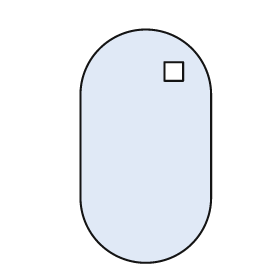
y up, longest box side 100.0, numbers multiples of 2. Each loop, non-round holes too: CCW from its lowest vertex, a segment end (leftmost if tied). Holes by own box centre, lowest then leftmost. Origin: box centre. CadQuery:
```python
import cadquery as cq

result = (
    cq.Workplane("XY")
    .moveTo(-28.0, -22.0)
    .threePointArc((0.0, -50.0), (28.0, -22.0))
    .lineTo(28.0, 22.0)
    .threePointArc((0.0, 50.0), (-28.0, 22.0))
    .close()
    .moveTo(8.0, 28.0)
    .lineTo(16.0, 28.0)
    .lineTo(16.0, 36.0)
    .lineTo(8.0, 36.0)
    .close()
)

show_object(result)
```